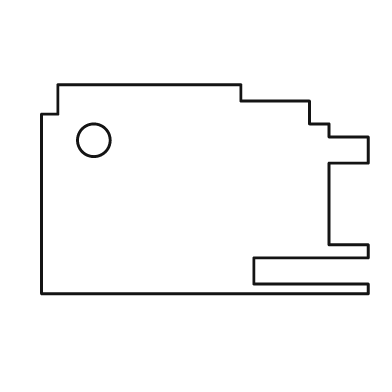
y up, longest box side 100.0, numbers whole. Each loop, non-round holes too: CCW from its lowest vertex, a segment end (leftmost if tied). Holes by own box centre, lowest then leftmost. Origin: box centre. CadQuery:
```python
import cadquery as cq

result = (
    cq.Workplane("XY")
    .moveTo(-50.0, -32.0)
    .lineTo(50.0, -32.0)
    .lineTo(50.0, -29.0)
    .lineTo(15.0, -29.0)
    .lineTo(15.0, -21.0)
    .lineTo(50.0, -21.0)
    .lineTo(50.0, -17.0)
    .lineTo(38.0, -17.0)
    .lineTo(38.0, 8.0)
    .lineTo(50.0, 8.0)
    .lineTo(50.0, 16.0)
    .lineTo(38.0, 16.0)
    .lineTo(38.0, 20.0)
    .lineTo(32.0, 20.0)
    .lineTo(32.0, 27.0)
    .lineTo(11.0, 27.0)
    .lineTo(11.0, 32.0)
    .lineTo(-45.0, 32.0)
    .lineTo(-45.0, 23.0)
    .lineTo(-50.0, 23.0)
    .close()
    .moveTo(-34.0, 15.0)
    .circle(5.0)
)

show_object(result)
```